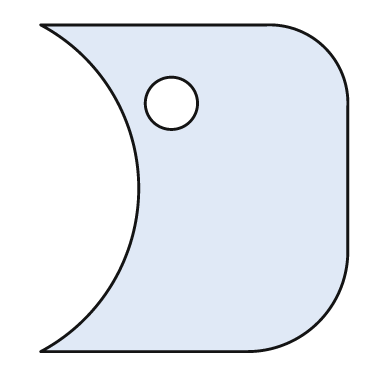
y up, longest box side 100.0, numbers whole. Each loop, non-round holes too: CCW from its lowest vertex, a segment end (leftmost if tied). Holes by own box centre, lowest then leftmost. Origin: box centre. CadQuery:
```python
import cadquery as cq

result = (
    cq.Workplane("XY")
    .moveTo(-47.0, -50.0)
    .lineTo(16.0, -50.0)
    .threePointArc((38.0, -41.0), (47.0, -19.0))
    .lineTo(47.0, 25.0)
    .threePointArc((40.0, 43.0), (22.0, 50.0))
    .lineTo(-47.0, 50.0)
    .threePointArc((-17.0, 0.0), (-47.0, -50.0))
    .close()
    .moveTo(-7.0, 26.0)
    .circle(8.0)
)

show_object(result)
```